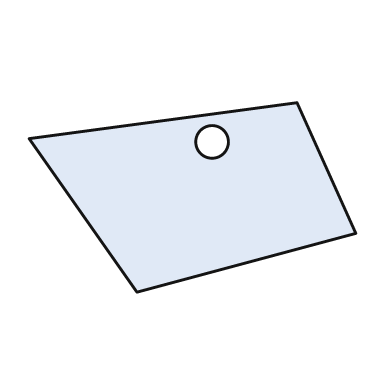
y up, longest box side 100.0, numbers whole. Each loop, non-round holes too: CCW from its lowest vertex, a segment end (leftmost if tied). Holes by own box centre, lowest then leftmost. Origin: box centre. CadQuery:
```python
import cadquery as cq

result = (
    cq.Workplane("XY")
    .moveTo(-17.0, -29.0)
    .lineTo(50.0, -11.0)
    .lineTo(32.0, 29.0)
    .lineTo(-50.0, 18.0)
    .close()
    .moveTo(6.0, 17.0)
    .circle(5.0)
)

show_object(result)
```